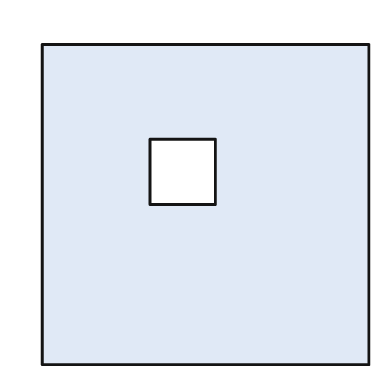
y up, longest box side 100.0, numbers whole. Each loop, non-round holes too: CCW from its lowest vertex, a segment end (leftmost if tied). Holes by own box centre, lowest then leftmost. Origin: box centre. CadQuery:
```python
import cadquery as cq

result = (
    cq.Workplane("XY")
    .moveTo(-50.0, -49.0)
    .lineTo(50.0, -49.0)
    .lineTo(50.0, 49.0)
    .lineTo(-50.0, 49.0)
    .close()
    .moveTo(-17.0, 0.0)
    .lineTo(3.0, 0.0)
    .lineTo(3.0, 20.0)
    .lineTo(-17.0, 20.0)
    .close()
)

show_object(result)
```